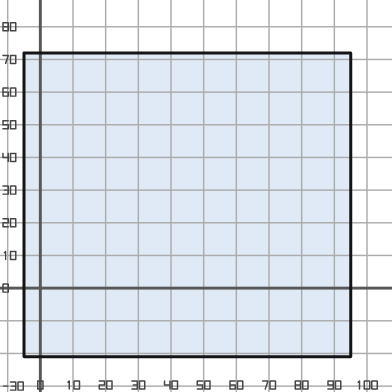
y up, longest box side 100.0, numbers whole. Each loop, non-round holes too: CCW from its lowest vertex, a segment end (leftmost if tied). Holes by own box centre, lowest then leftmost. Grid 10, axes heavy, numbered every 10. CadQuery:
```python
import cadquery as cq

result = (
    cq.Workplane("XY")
    .moveTo(-5.0, -21.0)
    .lineTo(95.0, -21.0)
    .lineTo(95.0, 72.0)
    .lineTo(-5.0, 72.0)
    .close()
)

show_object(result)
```